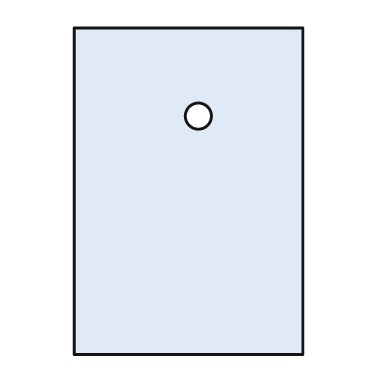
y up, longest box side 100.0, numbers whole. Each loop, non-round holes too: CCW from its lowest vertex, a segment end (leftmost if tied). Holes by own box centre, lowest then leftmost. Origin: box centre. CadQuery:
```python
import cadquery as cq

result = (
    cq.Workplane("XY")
    .moveTo(-35.0, -50.0)
    .lineTo(35.0, -50.0)
    .lineTo(35.0, 50.0)
    .lineTo(-35.0, 50.0)
    .close()
    .moveTo(3.0, 23.0)
    .circle(4.0)
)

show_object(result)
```